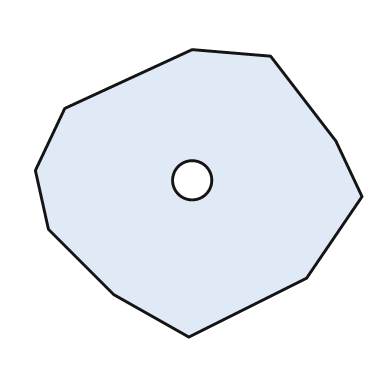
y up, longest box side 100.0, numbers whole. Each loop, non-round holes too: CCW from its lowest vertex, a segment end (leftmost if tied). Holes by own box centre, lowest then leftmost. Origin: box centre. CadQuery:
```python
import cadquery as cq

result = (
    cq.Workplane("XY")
    .moveTo(-3.0, -44.0)
    .lineTo(33.0, -26.0)
    .lineTo(50.0, -1.0)
    .lineTo(42.0, 16.0)
    .lineTo(22.0, 42.0)
    .lineTo(-2.0, 44.0)
    .lineTo(-41.0, 26.0)
    .lineTo(-50.0, 7.0)
    .lineTo(-46.0, -11.0)
    .lineTo(-26.0, -31.0)
    .close()
    .moveTo(-2.0, 4.0)
    .circle(6.0)
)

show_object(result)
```